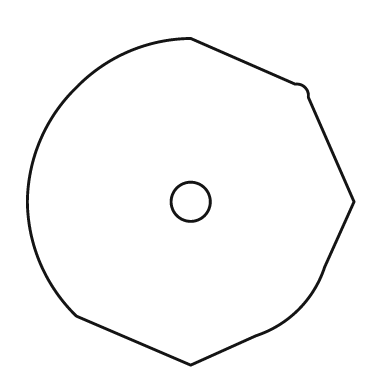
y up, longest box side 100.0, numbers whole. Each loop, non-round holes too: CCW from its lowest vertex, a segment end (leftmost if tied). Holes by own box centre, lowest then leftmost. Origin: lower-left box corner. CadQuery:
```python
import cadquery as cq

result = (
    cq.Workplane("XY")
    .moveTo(50.0, 0.0)
    .lineTo(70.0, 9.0)
    .threePointArc((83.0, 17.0), (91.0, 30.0))
    .lineTo(100.0, 50.0)
    .lineTo(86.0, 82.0)
    .threePointArc((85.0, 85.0), (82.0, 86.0))
    .lineTo(50.0, 100.0)
    .threePointArc((31.0, 96.0), (15.0, 85.0))
    .threePointArc((4.0, 69.0), (0.0, 50.0))
    .threePointArc((4.0, 31.0), (15.0, 15.0))
    .close()
    .moveTo(50.0, 50.0)
    .circle(6.0)
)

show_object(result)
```